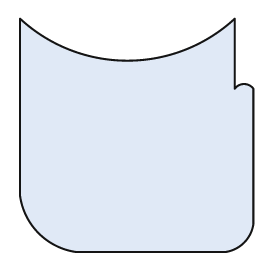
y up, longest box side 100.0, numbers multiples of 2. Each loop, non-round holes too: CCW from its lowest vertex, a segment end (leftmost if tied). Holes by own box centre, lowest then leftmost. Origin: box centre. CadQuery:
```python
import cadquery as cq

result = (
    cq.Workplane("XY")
    .moveTo(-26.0, -50.0)
    .lineTo(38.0, -50.0)
    .threePointArc((46.0, -46.0), (50.0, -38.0))
    .lineTo(50.0, 20.0)
    .threePointArc((46.0, 22.0), (42.0, 20.0))
    .lineTo(42.0, 50.0)
    .threePointArc((-4.0, 32.0), (-50.0, 50.0))
    .lineTo(-50.0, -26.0)
    .threePointArc((-42.0, -42.0), (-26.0, -50.0))
    .close()
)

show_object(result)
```